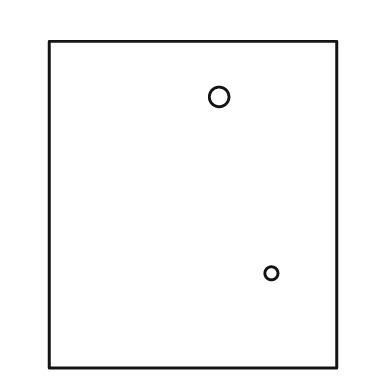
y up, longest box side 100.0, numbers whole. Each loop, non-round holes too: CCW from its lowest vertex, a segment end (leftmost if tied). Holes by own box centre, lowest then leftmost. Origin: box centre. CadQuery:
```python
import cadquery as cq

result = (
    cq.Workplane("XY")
    .moveTo(-44.0, -50.0)
    .lineTo(44.0, -50.0)
    .lineTo(44.0, 50.0)
    .lineTo(-44.0, 50.0)
    .close()
    .moveTo(24.0, -21.0)
    .circle(2.0)
    .moveTo(8.0, 33.0)
    .circle(3.0)
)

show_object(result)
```